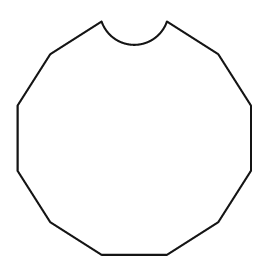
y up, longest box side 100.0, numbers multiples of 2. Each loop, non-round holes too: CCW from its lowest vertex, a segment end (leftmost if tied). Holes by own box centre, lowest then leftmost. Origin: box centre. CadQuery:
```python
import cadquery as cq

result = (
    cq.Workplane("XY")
    .moveTo(-14.0, -50.0)
    .lineTo(14.0, -50.0)
    .lineTo(36.0, -36.0)
    .lineTo(50.0, -14.0)
    .lineTo(50.0, 14.0)
    .lineTo(36.0, 36.0)
    .lineTo(14.0, 50.0)
    .threePointArc((0.0, 40.0), (-14.0, 50.0))
    .lineTo(-36.0, 36.0)
    .lineTo(-50.0, 14.0)
    .lineTo(-50.0, -14.0)
    .lineTo(-36.0, -36.0)
    .close()
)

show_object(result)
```